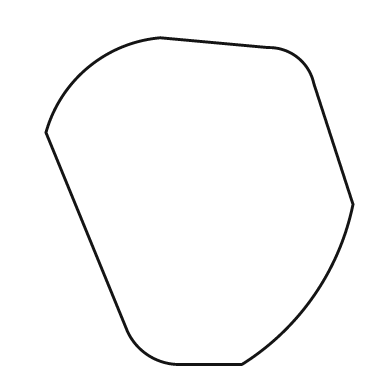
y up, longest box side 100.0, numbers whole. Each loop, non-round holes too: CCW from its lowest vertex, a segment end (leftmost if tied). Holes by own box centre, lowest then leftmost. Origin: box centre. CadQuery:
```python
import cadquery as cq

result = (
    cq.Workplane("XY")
    .moveTo(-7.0, -50.0)
    .lineTo(13.0, -50.0)
    .threePointArc((35.0, -29.0), (47.0, -1.0))
    .lineTo(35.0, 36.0)
    .threePointArc((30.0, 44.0), (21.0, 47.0))
    .lineTo(-12.0, 50.0)
    .threePointArc((-34.0, 41.0), (-47.0, 21.0))
    .lineTo(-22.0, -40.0)
    .threePointArc((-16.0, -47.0), (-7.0, -50.0))
    .close()
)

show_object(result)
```